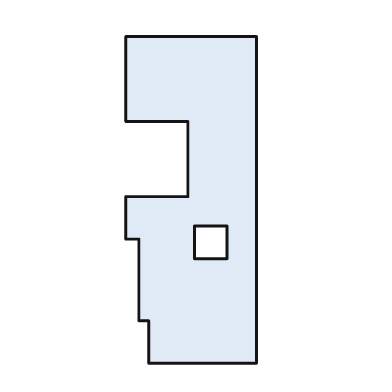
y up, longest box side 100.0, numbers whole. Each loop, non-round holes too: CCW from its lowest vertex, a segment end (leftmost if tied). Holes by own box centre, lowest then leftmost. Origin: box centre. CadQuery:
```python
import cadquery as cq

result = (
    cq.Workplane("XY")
    .moveTo(-13.0, -50.0)
    .lineTo(20.0, -50.0)
    .lineTo(20.0, 50.0)
    .lineTo(-20.0, 50.0)
    .lineTo(-20.0, 24.0)
    .lineTo(-1.0, 24.0)
    .lineTo(-1.0, 1.0)
    .lineTo(-20.0, 1.0)
    .lineTo(-20.0, -12.0)
    .lineTo(-16.0, -12.0)
    .lineTo(-16.0, -37.0)
    .lineTo(-13.0, -37.0)
    .close()
    .moveTo(1.0, -18.0)
    .lineTo(11.0, -18.0)
    .lineTo(11.0, -8.0)
    .lineTo(1.0, -8.0)
    .close()
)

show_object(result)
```